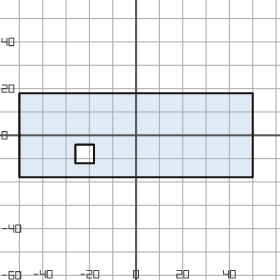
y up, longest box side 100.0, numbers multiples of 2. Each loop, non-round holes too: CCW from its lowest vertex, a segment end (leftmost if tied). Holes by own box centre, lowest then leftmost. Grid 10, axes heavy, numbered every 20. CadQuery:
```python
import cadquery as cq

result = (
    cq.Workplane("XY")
    .moveTo(-50.0, -18.0)
    .lineTo(50.0, -18.0)
    .lineTo(50.0, 18.0)
    .lineTo(-50.0, 18.0)
    .close()
    .moveTo(-26.0, -12.0)
    .lineTo(-18.0, -12.0)
    .lineTo(-18.0, -4.0)
    .lineTo(-26.0, -4.0)
    .close()
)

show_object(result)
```